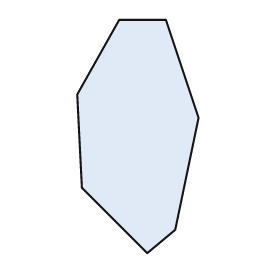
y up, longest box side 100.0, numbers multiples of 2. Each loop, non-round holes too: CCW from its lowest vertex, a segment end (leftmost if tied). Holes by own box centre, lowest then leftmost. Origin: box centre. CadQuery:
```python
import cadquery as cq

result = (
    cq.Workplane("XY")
    .moveTo(4.0, -50.0)
    .lineTo(16.0, -40.0)
    .lineTo(26.0, 8.0)
    .lineTo(12.0, 50.0)
    .lineTo(-8.0, 50.0)
    .lineTo(-26.0, 18.0)
    .lineTo(-24.0, -22.0)
    .close()
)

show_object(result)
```